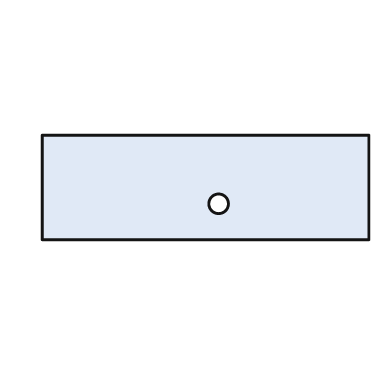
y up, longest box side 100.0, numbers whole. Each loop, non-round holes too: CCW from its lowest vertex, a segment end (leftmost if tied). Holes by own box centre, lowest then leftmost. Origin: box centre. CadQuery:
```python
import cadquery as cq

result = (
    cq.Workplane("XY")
    .moveTo(-50.0, -16.0)
    .lineTo(50.0, -16.0)
    .lineTo(50.0, 16.0)
    .lineTo(-50.0, 16.0)
    .close()
    .moveTo(4.0, -5.0)
    .circle(3.0)
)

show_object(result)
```